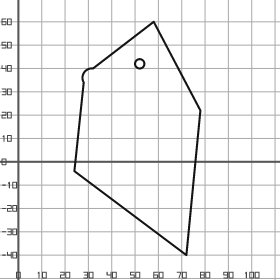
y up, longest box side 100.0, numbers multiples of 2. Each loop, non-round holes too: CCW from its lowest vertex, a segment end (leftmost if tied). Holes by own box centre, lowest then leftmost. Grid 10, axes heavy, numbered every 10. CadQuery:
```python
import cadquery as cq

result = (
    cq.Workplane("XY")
    .moveTo(72.0, -40.0)
    .lineTo(78.0, 22.0)
    .lineTo(58.0, 60.0)
    .lineTo(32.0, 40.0)
    .threePointArc((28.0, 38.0), (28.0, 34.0))
    .lineTo(24.0, -4.0)
    .close()
    .moveTo(52.0, 42.0)
    .circle(2.0)
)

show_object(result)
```